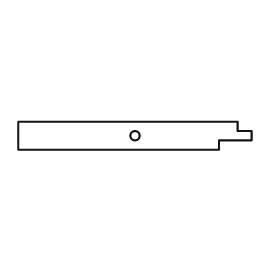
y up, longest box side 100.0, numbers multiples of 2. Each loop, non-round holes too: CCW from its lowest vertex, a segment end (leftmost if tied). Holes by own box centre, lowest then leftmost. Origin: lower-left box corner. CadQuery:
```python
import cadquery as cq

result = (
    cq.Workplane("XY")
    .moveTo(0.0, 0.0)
    .lineTo(86.0, 0.0)
    .lineTo(86.0, 4.0)
    .lineTo(100.0, 4.0)
    .lineTo(100.0, 8.0)
    .lineTo(94.0, 8.0)
    .lineTo(94.0, 12.0)
    .lineTo(0.0, 12.0)
    .close()
    .moveTo(50.0, 6.0)
    .circle(2.0)
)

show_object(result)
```